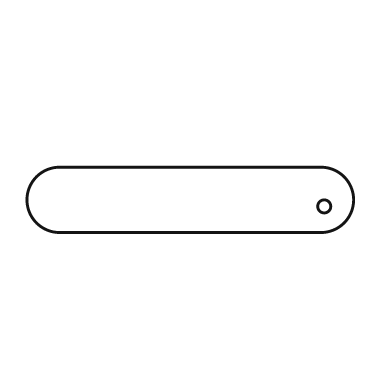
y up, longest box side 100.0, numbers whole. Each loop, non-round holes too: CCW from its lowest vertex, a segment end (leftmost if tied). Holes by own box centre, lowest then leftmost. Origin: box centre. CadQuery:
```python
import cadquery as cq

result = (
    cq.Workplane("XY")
    .moveTo(-40.0, -10.0)
    .lineTo(40.0, -10.0)
    .threePointArc((50.0, 0.0), (40.0, 10.0))
    .lineTo(-40.0, 10.0)
    .threePointArc((-50.0, 0.0), (-40.0, -10.0))
    .close()
    .moveTo(41.0, -2.0)
    .circle(2.0)
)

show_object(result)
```